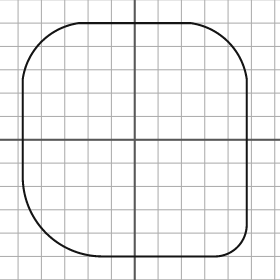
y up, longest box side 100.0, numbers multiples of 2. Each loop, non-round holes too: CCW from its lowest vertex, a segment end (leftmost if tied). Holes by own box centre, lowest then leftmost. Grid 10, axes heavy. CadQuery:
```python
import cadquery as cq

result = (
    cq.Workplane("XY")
    .moveTo(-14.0, -50.0)
    .lineTo(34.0, -50.0)
    .threePointArc((44.0, -46.0), (48.0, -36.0))
    .lineTo(48.0, 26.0)
    .threePointArc((40.0, 42.0), (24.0, 50.0))
    .lineTo(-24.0, 50.0)
    .threePointArc((-40.0, 42.0), (-48.0, 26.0))
    .lineTo(-48.0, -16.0)
    .threePointArc((-38.0, -40.0), (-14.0, -50.0))
    .close()
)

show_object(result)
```